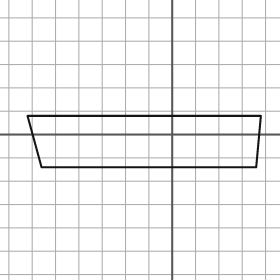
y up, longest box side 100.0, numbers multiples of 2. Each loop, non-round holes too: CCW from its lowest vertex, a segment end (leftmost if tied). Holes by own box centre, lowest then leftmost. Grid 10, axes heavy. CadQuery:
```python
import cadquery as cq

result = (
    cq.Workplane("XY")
    .moveTo(-56.0, -14.0)
    .lineTo(36.0, -14.0)
    .lineTo(38.0, 8.0)
    .lineTo(-62.0, 8.0)
    .close()
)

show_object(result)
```